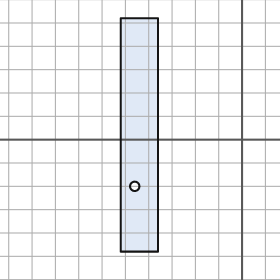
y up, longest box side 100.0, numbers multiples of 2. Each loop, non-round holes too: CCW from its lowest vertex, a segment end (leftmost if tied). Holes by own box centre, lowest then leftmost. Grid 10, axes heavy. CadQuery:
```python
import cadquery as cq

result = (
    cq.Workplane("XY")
    .moveTo(-52.0, -48.0)
    .lineTo(-36.0, -48.0)
    .lineTo(-36.0, 52.0)
    .lineTo(-52.0, 52.0)
    .close()
    .moveTo(-46.0, -20.0)
    .circle(2.0)
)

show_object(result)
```